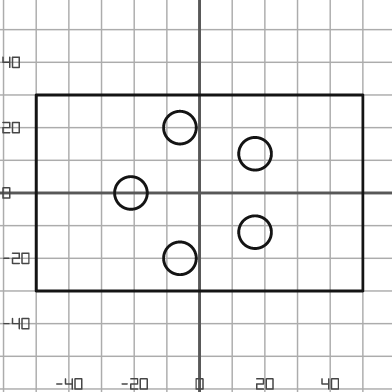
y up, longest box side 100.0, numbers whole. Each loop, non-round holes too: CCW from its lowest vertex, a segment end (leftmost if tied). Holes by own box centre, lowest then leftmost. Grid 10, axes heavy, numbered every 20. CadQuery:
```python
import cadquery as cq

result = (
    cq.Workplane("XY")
    .moveTo(-50.0, -30.0)
    .lineTo(50.0, -30.0)
    .lineTo(50.0, 30.0)
    .lineTo(-50.0, 30.0)
    .close()
    .moveTo(-6.0, -20.0)
    .circle(5.0)
    .moveTo(17.0, -12.0)
    .circle(5.0)
    .moveTo(-21.0, 0.0)
    .circle(5.0)
    .moveTo(17.0, 12.0)
    .circle(5.0)
    .moveTo(-6.0, 20.0)
    .circle(5.0)
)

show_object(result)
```